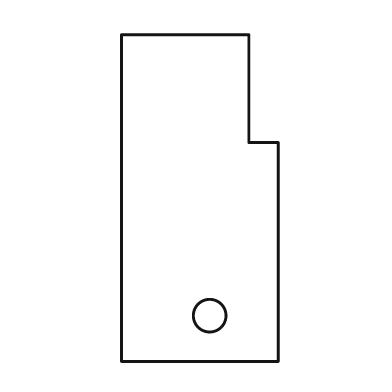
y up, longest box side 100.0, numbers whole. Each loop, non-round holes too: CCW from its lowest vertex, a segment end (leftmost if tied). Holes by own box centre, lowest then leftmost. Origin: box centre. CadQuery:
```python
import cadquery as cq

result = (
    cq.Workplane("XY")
    .moveTo(-24.0, -50.0)
    .lineTo(24.0, -50.0)
    .lineTo(24.0, 17.0)
    .lineTo(15.0, 17.0)
    .lineTo(15.0, 50.0)
    .lineTo(-24.0, 50.0)
    .close()
    .moveTo(3.0, -36.0)
    .circle(5.0)
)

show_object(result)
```